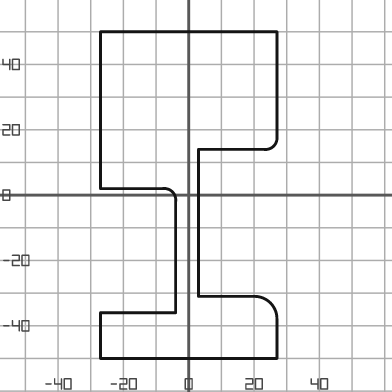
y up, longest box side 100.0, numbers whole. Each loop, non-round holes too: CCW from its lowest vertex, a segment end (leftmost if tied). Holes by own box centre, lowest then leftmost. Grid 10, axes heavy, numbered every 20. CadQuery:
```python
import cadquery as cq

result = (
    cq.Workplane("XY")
    .moveTo(-27.0, -50.0)
    .lineTo(27.0, -50.0)
    .lineTo(27.0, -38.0)
    .threePointArc((25.0, -33.0), (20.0, -31.0))
    .lineTo(3.0, -31.0)
    .lineTo(3.0, 14.0)
    .lineTo(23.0, 14.0)
    .threePointArc((26.0, 15.0), (27.0, 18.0))
    .lineTo(27.0, 50.0)
    .lineTo(-27.0, 50.0)
    .lineTo(-27.0, 2.0)
    .lineTo(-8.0, 2.0)
    .threePointArc((-5.0, 1.0), (-4.0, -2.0))
    .lineTo(-4.0, -36.0)
    .lineTo(-27.0, -36.0)
    .close()
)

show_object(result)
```